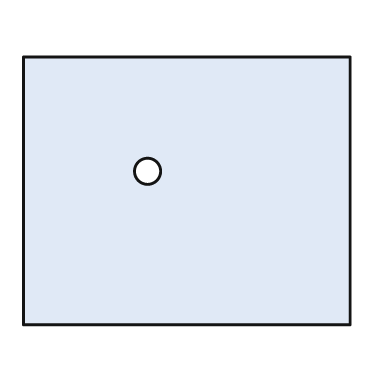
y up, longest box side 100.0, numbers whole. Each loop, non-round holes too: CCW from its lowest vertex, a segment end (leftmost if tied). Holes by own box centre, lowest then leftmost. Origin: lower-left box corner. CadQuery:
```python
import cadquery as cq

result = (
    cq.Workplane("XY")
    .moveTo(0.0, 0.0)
    .lineTo(100.0, 0.0)
    .lineTo(100.0, 82.0)
    .lineTo(0.0, 82.0)
    .close()
    .moveTo(38.0, 47.0)
    .circle(4.0)
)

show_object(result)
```